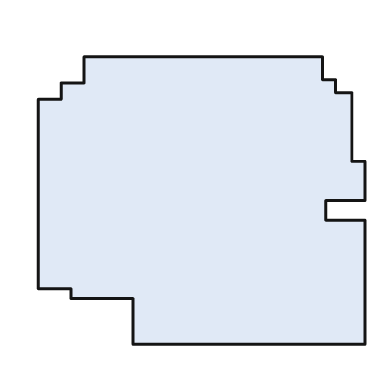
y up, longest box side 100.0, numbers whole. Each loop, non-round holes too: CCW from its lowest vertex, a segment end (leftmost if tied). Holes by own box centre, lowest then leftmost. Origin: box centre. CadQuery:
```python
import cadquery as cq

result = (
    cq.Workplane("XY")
    .moveTo(-21.0, -44.0)
    .lineTo(50.0, -44.0)
    .lineTo(50.0, -6.0)
    .lineTo(38.0, -6.0)
    .lineTo(38.0, 0.0)
    .lineTo(50.0, 0.0)
    .lineTo(50.0, 12.0)
    .lineTo(46.0, 12.0)
    .lineTo(46.0, 33.0)
    .lineTo(41.0, 33.0)
    .lineTo(41.0, 37.0)
    .lineTo(37.0, 37.0)
    .lineTo(37.0, 44.0)
    .lineTo(-36.0, 44.0)
    .lineTo(-36.0, 36.0)
    .lineTo(-43.0, 36.0)
    .lineTo(-43.0, 31.0)
    .lineTo(-50.0, 31.0)
    .lineTo(-50.0, -27.0)
    .lineTo(-40.0, -27.0)
    .lineTo(-40.0, -30.0)
    .lineTo(-21.0, -30.0)
    .close()
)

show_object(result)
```